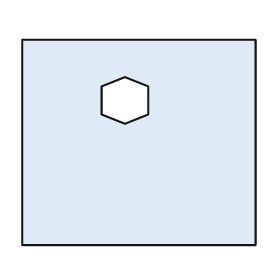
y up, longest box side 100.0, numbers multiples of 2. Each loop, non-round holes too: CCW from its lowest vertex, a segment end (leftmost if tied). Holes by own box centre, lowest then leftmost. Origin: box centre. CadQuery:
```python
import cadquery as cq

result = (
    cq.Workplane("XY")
    .moveTo(-50.0, -44.0)
    .lineTo(50.0, -44.0)
    .lineTo(50.0, 44.0)
    .lineTo(-50.0, 44.0)
    .close()
    .moveTo(-6.0, 8.0)
    .lineTo(4.0, 12.0)
    .lineTo(4.0, 24.0)
    .lineTo(-6.0, 28.0)
    .lineTo(-16.0, 24.0)
    .lineTo(-16.0, 12.0)
    .close()
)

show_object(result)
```